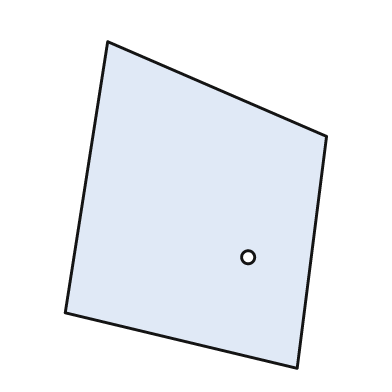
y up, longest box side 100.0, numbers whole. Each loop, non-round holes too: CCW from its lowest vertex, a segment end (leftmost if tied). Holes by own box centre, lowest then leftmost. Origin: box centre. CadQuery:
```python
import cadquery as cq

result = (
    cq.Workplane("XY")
    .moveTo(31.0, -50.0)
    .lineTo(40.0, 21.0)
    .lineTo(-27.0, 50.0)
    .lineTo(-40.0, -33.0)
    .close()
    .moveTo(16.0, -16.0)
    .circle(2.0)
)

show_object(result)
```